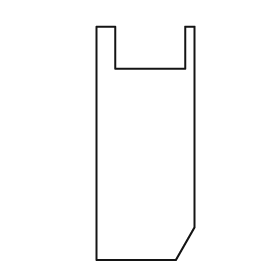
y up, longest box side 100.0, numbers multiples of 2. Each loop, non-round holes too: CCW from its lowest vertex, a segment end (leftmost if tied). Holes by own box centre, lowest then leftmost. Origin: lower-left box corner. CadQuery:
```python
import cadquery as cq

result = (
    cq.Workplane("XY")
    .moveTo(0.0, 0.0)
    .lineTo(34.0, 0.0)
    .lineTo(42.0, 14.0)
    .lineTo(42.0, 100.0)
    .lineTo(38.0, 100.0)
    .lineTo(38.0, 82.0)
    .lineTo(8.0, 82.0)
    .lineTo(8.0, 100.0)
    .lineTo(0.0, 100.0)
    .close()
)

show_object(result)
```